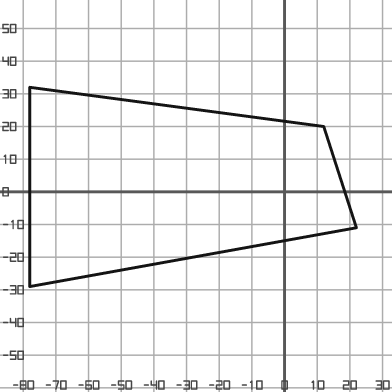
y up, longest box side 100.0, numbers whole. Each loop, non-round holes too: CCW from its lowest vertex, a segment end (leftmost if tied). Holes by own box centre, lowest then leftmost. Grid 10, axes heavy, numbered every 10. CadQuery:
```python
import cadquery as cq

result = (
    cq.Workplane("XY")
    .moveTo(-78.0, -29.0)
    .lineTo(22.0, -11.0)
    .lineTo(12.0, 20.0)
    .lineTo(-78.0, 32.0)
    .close()
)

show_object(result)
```